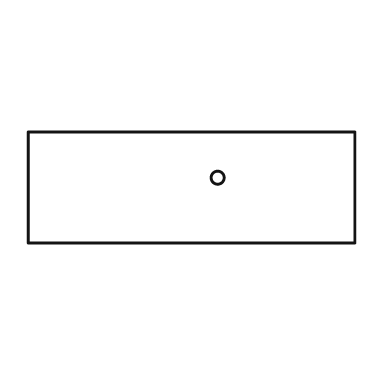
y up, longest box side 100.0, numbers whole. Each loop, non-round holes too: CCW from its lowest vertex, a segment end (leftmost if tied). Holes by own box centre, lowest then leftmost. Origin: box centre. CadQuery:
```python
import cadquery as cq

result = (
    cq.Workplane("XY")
    .moveTo(-50.0, -17.0)
    .lineTo(50.0, -17.0)
    .lineTo(50.0, 17.0)
    .lineTo(-50.0, 17.0)
    .close()
    .moveTo(8.0, 3.0)
    .circle(2.0)
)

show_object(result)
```